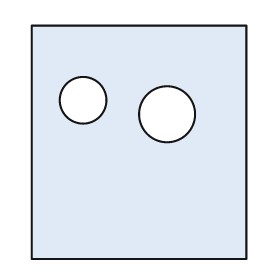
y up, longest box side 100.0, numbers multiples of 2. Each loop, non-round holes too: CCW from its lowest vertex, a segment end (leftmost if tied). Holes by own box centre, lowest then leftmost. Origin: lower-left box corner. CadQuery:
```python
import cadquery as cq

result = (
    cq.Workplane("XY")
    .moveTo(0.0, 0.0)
    .lineTo(92.0, 0.0)
    .lineTo(92.0, 100.0)
    .lineTo(0.0, 100.0)
    .close()
    .moveTo(58.0, 62.0)
    .circle(12.0)
    .moveTo(22.0, 68.0)
    .circle(10.0)
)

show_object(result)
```